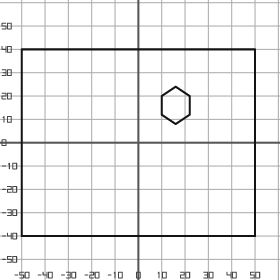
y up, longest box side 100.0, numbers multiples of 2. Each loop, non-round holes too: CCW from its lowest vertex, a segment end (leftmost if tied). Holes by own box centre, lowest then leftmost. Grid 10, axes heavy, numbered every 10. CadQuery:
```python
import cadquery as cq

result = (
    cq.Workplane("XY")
    .moveTo(-50.0, -40.0)
    .lineTo(50.0, -40.0)
    .lineTo(50.0, 40.0)
    .lineTo(-50.0, 40.0)
    .close()
    .moveTo(16.0, 8.0)
    .lineTo(22.0, 12.0)
    .lineTo(22.0, 20.0)
    .lineTo(16.0, 24.0)
    .lineTo(10.0, 20.0)
    .lineTo(10.0, 12.0)
    .close()
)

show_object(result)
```